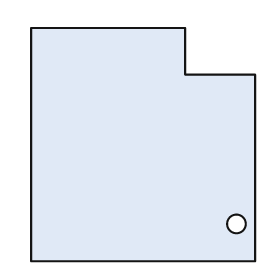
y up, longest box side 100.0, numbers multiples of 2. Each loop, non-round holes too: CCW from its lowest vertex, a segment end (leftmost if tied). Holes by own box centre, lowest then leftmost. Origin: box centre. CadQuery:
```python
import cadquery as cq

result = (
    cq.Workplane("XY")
    .moveTo(-48.0, -50.0)
    .lineTo(48.0, -50.0)
    .lineTo(48.0, 30.0)
    .lineTo(18.0, 30.0)
    .lineTo(18.0, 50.0)
    .lineTo(-48.0, 50.0)
    .close()
    .moveTo(40.0, -34.0)
    .circle(4.0)
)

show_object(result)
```